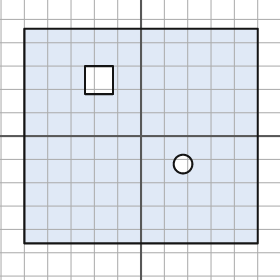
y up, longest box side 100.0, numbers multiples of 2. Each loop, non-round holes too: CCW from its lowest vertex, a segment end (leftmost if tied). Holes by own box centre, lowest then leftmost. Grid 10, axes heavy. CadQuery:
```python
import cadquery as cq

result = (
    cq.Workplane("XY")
    .moveTo(-50.0, -46.0)
    .lineTo(50.0, -46.0)
    .lineTo(50.0, 46.0)
    .lineTo(-50.0, 46.0)
    .close()
    .moveTo(18.0, -12.0)
    .circle(4.0)
    .moveTo(-24.0, 18.0)
    .lineTo(-12.0, 18.0)
    .lineTo(-12.0, 30.0)
    .lineTo(-24.0, 30.0)
    .close()
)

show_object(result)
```